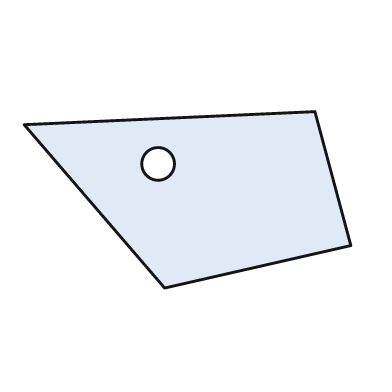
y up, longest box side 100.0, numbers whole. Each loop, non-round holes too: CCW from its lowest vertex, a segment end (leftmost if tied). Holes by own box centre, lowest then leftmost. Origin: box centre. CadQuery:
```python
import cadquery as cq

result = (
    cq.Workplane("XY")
    .moveTo(-7.0, -27.0)
    .lineTo(50.0, -14.0)
    .lineTo(39.0, 27.0)
    .lineTo(-50.0, 23.0)
    .close()
    .moveTo(-9.0, 11.0)
    .circle(5.0)
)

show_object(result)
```